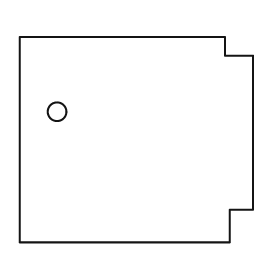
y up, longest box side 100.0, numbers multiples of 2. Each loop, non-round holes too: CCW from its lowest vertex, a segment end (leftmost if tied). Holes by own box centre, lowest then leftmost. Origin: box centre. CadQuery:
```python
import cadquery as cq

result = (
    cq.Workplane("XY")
    .moveTo(-50.0, -44.0)
    .lineTo(40.0, -44.0)
    .lineTo(40.0, -30.0)
    .lineTo(50.0, -30.0)
    .lineTo(50.0, 36.0)
    .lineTo(38.0, 36.0)
    .lineTo(38.0, 44.0)
    .lineTo(-50.0, 44.0)
    .close()
    .moveTo(-34.0, 12.0)
    .circle(4.0)
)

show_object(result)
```